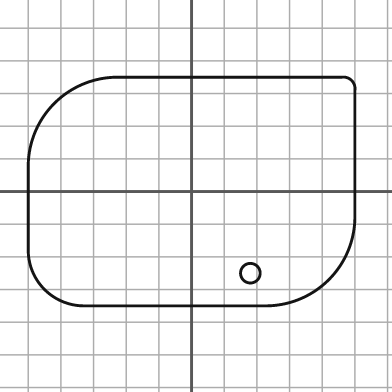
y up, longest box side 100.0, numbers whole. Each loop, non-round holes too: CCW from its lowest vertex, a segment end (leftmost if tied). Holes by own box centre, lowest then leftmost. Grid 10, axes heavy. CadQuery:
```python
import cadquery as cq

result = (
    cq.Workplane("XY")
    .moveTo(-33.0, -35.0)
    .lineTo(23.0, -35.0)
    .threePointArc((42.0, -27.0), (50.0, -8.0))
    .lineTo(50.0, 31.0)
    .threePointArc((49.0, 34.0), (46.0, 35.0))
    .lineTo(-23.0, 35.0)
    .threePointArc((-42.0, 27.0), (-50.0, 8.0))
    .lineTo(-50.0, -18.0)
    .threePointArc((-45.0, -30.0), (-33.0, -35.0))
    .close()
    .moveTo(18.0, -25.0)
    .circle(3.0)
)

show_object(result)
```